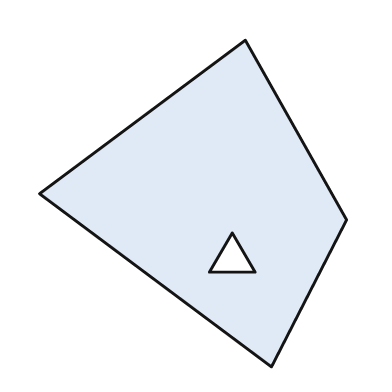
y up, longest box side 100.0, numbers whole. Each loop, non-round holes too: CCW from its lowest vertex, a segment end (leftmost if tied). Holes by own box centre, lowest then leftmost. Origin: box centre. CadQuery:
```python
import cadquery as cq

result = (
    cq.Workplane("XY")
    .moveTo(24.0, -50.0)
    .lineTo(47.0, -5.0)
    .lineTo(16.0, 50.0)
    .lineTo(-47.0, 3.0)
    .close()
    .moveTo(5.0, -21.0)
    .lineTo(19.0, -21.0)
    .lineTo(12.0, -9.0)
    .close()
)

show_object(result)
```